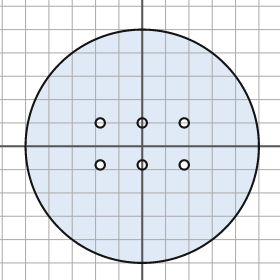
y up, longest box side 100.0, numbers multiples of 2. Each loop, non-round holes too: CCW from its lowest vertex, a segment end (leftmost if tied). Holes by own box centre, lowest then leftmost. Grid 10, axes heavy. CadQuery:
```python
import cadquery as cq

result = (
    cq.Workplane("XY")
    .moveTo(0.0, 0.0)
    .circle(50.0)
    .moveTo(-18.0, -8.0)
    .circle(2.0)
    .moveTo(0.0, -8.0)
    .circle(2.0)
    .moveTo(18.0, -8.0)
    .circle(2.0)
    .moveTo(-18.0, 10.0)
    .circle(2.0)
    .moveTo(0.0, 10.0)
    .circle(2.0)
    .moveTo(18.0, 10.0)
    .circle(2.0)
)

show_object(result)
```